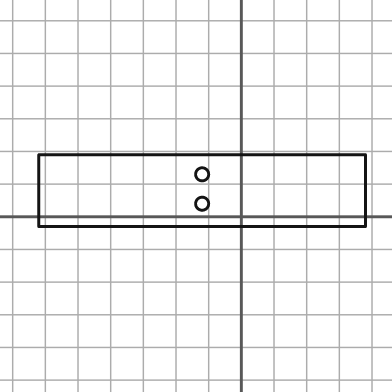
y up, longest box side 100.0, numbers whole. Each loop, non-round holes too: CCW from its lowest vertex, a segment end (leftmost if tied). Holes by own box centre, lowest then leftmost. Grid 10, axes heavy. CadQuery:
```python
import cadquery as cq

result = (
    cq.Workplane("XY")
    .moveTo(-62.0, -3.0)
    .lineTo(38.0, -3.0)
    .lineTo(38.0, 19.0)
    .lineTo(-62.0, 19.0)
    .close()
    .moveTo(-12.0, 4.0)
    .circle(2.0)
    .moveTo(-12.0, 13.0)
    .circle(2.0)
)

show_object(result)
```